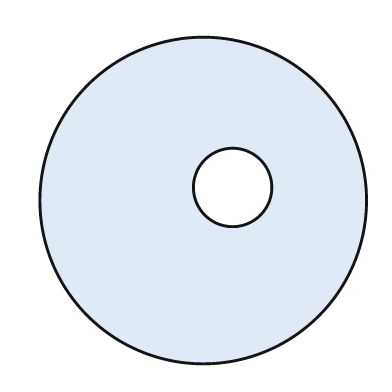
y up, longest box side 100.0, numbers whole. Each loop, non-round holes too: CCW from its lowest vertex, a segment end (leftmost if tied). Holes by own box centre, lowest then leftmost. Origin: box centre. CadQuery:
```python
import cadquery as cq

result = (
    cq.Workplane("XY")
    .moveTo(0.0, 0.0)
    .circle(50.0)
    .moveTo(9.0, 4.0)
    .circle(12.0)
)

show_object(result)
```